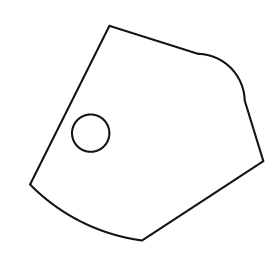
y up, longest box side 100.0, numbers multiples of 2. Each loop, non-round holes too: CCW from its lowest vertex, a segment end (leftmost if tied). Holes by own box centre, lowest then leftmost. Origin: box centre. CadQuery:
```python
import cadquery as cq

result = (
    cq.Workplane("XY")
    .moveTo(-2.0, -46.0)
    .lineTo(50.0, -12.0)
    .lineTo(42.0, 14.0)
    .threePointArc((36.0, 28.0), (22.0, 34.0))
    .lineTo(-16.0, 46.0)
    .lineTo(-50.0, -22.0)
    .threePointArc((-28.0, -38.0), (-2.0, -46.0))
    .close()
    .moveTo(-24.0, 0.0)
    .circle(8.0)
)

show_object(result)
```